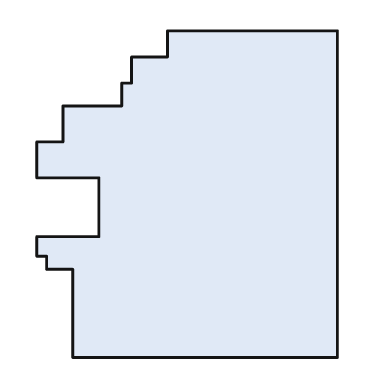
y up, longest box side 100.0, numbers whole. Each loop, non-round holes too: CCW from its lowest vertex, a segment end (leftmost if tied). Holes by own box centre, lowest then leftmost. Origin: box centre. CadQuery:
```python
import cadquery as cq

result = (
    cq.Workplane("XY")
    .moveTo(-35.0, -50.0)
    .lineTo(46.0, -50.0)
    .lineTo(46.0, 50.0)
    .lineTo(-6.0, 50.0)
    .lineTo(-6.0, 42.0)
    .lineTo(-17.0, 42.0)
    .lineTo(-17.0, 34.0)
    .lineTo(-20.0, 34.0)
    .lineTo(-20.0, 27.0)
    .lineTo(-38.0, 27.0)
    .lineTo(-38.0, 16.0)
    .lineTo(-46.0, 16.0)
    .lineTo(-46.0, 5.0)
    .lineTo(-27.0, 5.0)
    .lineTo(-27.0, -13.0)
    .lineTo(-46.0, -13.0)
    .lineTo(-46.0, -19.0)
    .lineTo(-43.0, -19.0)
    .lineTo(-43.0, -23.0)
    .lineTo(-35.0, -23.0)
    .close()
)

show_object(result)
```